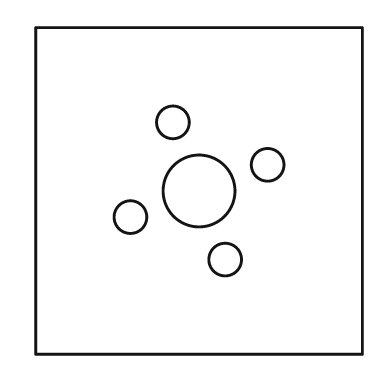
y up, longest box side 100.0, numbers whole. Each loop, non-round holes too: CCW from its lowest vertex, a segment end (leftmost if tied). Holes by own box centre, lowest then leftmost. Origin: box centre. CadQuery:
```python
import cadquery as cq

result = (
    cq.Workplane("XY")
    .moveTo(-50.0, -50.0)
    .lineTo(50.0, -50.0)
    .lineTo(50.0, 50.0)
    .lineTo(-50.0, 50.0)
    .close()
    .moveTo(8.0, -21.0)
    .circle(5.0)
    .moveTo(-21.0, -8.0)
    .circle(5.0)
    .moveTo(0.0, 0.0)
    .circle(11.0)
    .moveTo(21.0, 8.0)
    .circle(5.0)
    .moveTo(-8.0, 21.0)
    .circle(5.0)
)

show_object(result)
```